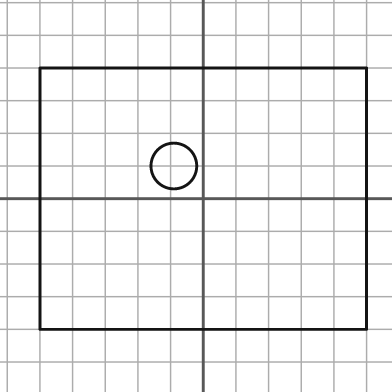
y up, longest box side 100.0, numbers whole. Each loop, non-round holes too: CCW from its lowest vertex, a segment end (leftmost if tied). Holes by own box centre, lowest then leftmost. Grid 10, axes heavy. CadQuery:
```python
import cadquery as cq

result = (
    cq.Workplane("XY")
    .moveTo(-50.0, -40.0)
    .lineTo(50.0, -40.0)
    .lineTo(50.0, 40.0)
    .lineTo(-50.0, 40.0)
    .close()
    .moveTo(-9.0, 10.0)
    .circle(7.0)
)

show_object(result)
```